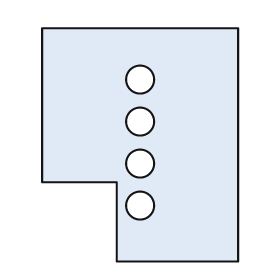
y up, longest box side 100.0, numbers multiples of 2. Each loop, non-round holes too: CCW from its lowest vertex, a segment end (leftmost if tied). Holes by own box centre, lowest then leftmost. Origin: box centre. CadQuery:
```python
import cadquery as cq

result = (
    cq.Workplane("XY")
    .moveTo(-10.0, -50.0)
    .lineTo(42.0, -50.0)
    .lineTo(42.0, 50.0)
    .lineTo(-42.0, 50.0)
    .lineTo(-42.0, -16.0)
    .lineTo(-10.0, -16.0)
    .close()
    .moveTo(0.0, -26.0)
    .circle(6.0)
    .moveTo(0.0, -8.0)
    .circle(6.0)
    .moveTo(0.0, 10.0)
    .circle(6.0)
    .moveTo(0.0, 28.0)
    .circle(6.0)
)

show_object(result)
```